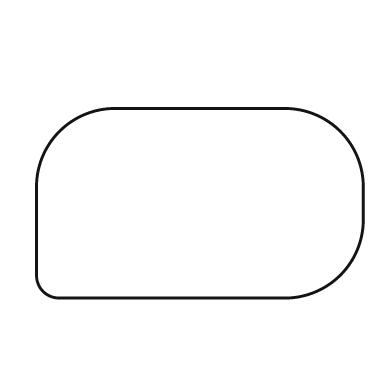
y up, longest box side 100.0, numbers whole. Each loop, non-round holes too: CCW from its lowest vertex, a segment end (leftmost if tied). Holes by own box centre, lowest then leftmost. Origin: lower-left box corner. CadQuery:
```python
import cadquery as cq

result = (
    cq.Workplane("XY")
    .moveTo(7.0, 0.0)
    .lineTo(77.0, 0.0)
    .threePointArc((93.0, 7.0), (100.0, 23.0))
    .lineTo(100.0, 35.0)
    .threePointArc((93.0, 51.0), (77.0, 58.0))
    .lineTo(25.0, 58.0)
    .threePointArc((7.0, 51.0), (0.0, 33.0))
    .lineTo(0.0, 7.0)
    .threePointArc((2.0, 2.0), (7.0, 0.0))
    .close()
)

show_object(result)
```